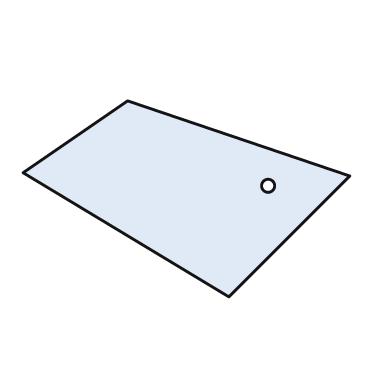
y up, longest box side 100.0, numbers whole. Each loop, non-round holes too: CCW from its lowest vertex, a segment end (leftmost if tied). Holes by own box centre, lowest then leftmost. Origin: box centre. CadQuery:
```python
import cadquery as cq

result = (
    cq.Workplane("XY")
    .moveTo(13.0, -30.0)
    .lineTo(50.0, 7.0)
    .lineTo(-18.0, 30.0)
    .lineTo(-50.0, 8.0)
    .close()
    .moveTo(25.0, 4.0)
    .circle(2.0)
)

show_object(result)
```